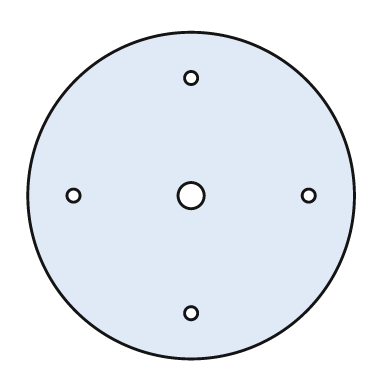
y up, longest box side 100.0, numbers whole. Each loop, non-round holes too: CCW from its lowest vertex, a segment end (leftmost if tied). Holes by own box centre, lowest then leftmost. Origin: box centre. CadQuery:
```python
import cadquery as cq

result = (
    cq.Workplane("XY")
    .moveTo(0.0, 0.0)
    .circle(50.0)
    .moveTo(0.0, -36.0)
    .circle(2.0)
    .moveTo(-36.0, 0.0)
    .circle(2.0)
    .moveTo(0.0, 0.0)
    .circle(4.0)
    .moveTo(36.0, 0.0)
    .circle(2.0)
    .moveTo(0.0, 36.0)
    .circle(2.0)
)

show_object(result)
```